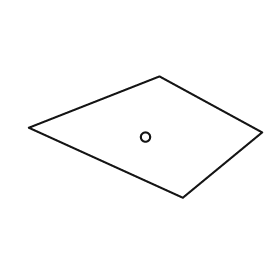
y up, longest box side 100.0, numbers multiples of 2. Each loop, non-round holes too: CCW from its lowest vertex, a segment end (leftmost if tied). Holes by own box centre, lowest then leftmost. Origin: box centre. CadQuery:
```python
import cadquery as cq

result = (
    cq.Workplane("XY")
    .moveTo(16.0, -26.0)
    .lineTo(50.0, 2.0)
    .lineTo(6.0, 26.0)
    .lineTo(-50.0, 4.0)
    .close()
    .moveTo(0.0, 0.0)
    .circle(2.0)
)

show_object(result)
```